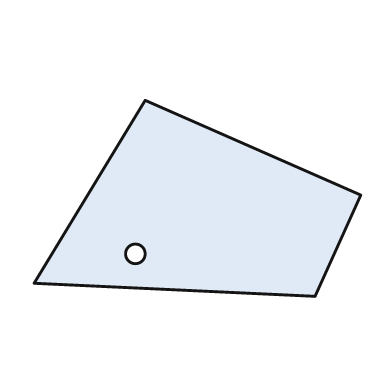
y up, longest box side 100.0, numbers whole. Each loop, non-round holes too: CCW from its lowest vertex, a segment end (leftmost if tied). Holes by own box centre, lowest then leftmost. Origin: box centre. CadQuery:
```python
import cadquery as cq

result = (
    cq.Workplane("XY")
    .moveTo(36.0, -30.0)
    .lineTo(50.0, 1.0)
    .lineTo(-16.0, 30.0)
    .lineTo(-50.0, -26.0)
    .close()
    .moveTo(-19.0, -17.0)
    .circle(3.0)
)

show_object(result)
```